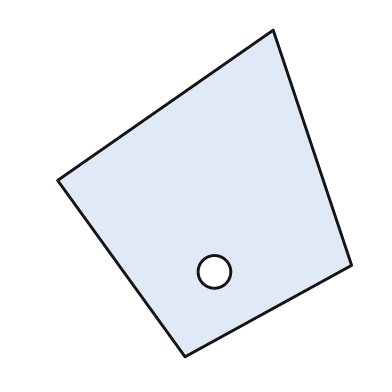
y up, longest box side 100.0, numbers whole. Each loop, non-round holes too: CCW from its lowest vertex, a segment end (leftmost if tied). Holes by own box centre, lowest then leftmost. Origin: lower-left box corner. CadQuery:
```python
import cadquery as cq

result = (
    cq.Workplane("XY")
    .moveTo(39.0, 0.0)
    .lineTo(90.0, 28.0)
    .lineTo(66.0, 100.0)
    .lineTo(0.0, 54.0)
    .close()
    .moveTo(48.0, 26.0)
    .circle(5.0)
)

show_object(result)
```